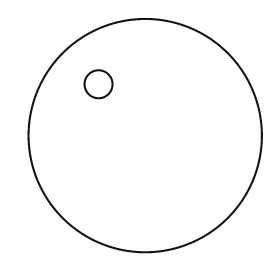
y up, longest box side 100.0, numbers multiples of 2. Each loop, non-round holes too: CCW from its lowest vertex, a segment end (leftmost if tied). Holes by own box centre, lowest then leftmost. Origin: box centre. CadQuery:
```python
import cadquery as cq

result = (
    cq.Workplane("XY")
    .moveTo(0.0, 0.0)
    .circle(50.0)
    .moveTo(-20.0, 22.0)
    .circle(6.0)
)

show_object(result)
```